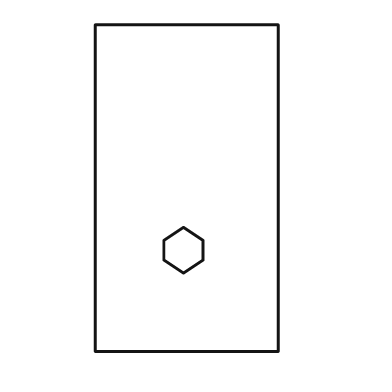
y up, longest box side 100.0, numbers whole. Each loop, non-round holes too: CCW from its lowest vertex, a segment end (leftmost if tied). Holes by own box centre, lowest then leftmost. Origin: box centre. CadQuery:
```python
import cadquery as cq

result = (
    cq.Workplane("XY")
    .moveTo(-28.0, -50.0)
    .lineTo(28.0, -50.0)
    .lineTo(28.0, 50.0)
    .lineTo(-28.0, 50.0)
    .close()
    .moveTo(-1.0, -26.0)
    .lineTo(5.0, -22.0)
    .lineTo(5.0, -16.0)
    .lineTo(-1.0, -12.0)
    .lineTo(-7.0, -16.0)
    .lineTo(-7.0, -22.0)
    .close()
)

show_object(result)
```